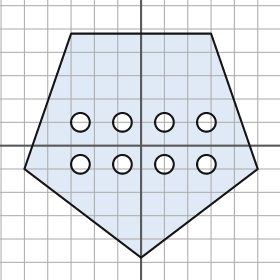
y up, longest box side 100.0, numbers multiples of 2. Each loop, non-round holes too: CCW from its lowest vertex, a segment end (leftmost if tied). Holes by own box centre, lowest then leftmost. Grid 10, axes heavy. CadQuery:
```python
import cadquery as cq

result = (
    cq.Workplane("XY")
    .moveTo(0.0, -48.0)
    .lineTo(50.0, -10.0)
    .lineTo(30.0, 48.0)
    .lineTo(-30.0, 48.0)
    .lineTo(-50.0, -10.0)
    .close()
    .moveTo(-26.0, -8.0)
    .circle(4.0)
    .moveTo(-8.0, -8.0)
    .circle(4.0)
    .moveTo(10.0, -8.0)
    .circle(4.0)
    .moveTo(28.0, -8.0)
    .circle(4.0)
    .moveTo(-26.0, 10.0)
    .circle(4.0)
    .moveTo(-8.0, 10.0)
    .circle(4.0)
    .moveTo(10.0, 10.0)
    .circle(4.0)
    .moveTo(28.0, 10.0)
    .circle(4.0)
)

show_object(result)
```